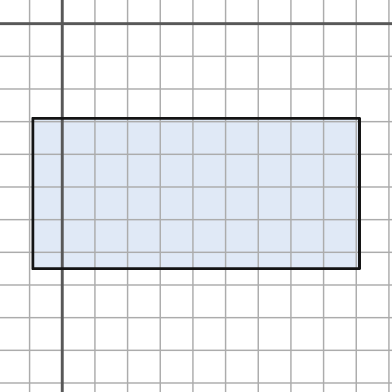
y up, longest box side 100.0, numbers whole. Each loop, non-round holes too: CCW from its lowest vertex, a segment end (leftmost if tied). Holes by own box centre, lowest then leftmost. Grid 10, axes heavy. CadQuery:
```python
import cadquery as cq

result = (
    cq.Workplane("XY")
    .moveTo(-9.0, -75.0)
    .lineTo(91.0, -75.0)
    .lineTo(91.0, -29.0)
    .lineTo(-9.0, -29.0)
    .close()
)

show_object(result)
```